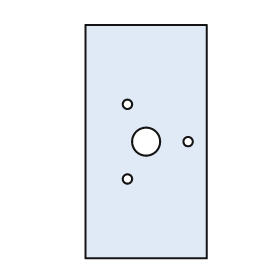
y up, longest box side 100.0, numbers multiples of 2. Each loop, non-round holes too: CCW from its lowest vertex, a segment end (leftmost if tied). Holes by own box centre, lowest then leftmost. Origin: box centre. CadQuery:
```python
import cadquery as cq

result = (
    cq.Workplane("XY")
    .moveTo(-26.0, -50.0)
    .lineTo(26.0, -50.0)
    .lineTo(26.0, 50.0)
    .lineTo(-26.0, 50.0)
    .close()
    .moveTo(-8.0, -16.0)
    .circle(2.0)
    .moveTo(0.0, 0.0)
    .circle(6.0)
    .moveTo(18.0, 0.0)
    .circle(2.0)
    .moveTo(-8.0, 16.0)
    .circle(2.0)
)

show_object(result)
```